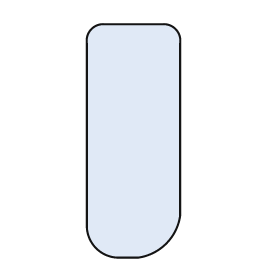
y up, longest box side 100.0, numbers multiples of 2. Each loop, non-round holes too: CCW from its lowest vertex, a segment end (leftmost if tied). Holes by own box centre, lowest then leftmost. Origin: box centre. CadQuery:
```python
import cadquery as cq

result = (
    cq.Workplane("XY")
    .moveTo(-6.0, -50.0)
    .lineTo(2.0, -50.0)
    .threePointArc((14.0, -44.0), (20.0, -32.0))
    .lineTo(20.0, 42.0)
    .threePointArc((18.0, 48.0), (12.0, 50.0))
    .lineTo(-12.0, 50.0)
    .threePointArc((-18.0, 48.0), (-20.0, 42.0))
    .lineTo(-20.0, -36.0)
    .threePointArc((-16.0, -46.0), (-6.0, -50.0))
    .close()
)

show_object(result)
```